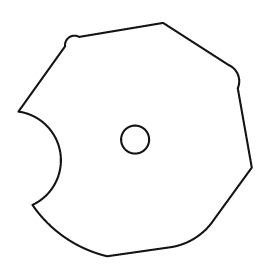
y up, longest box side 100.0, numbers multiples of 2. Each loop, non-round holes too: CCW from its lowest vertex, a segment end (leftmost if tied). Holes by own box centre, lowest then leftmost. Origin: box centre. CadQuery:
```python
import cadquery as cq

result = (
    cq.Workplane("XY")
    .moveTo(-12.0, -50.0)
    .lineTo(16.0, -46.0)
    .threePointArc((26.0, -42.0), (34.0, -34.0))
    .lineTo(50.0, -12.0)
    .lineTo(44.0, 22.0)
    .threePointArc((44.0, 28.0), (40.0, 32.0))
    .lineTo(12.0, 50.0)
    .lineTo(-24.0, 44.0)
    .threePointArc((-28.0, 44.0), (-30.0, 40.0))
    .lineTo(-50.0, 12.0)
    .threePointArc((-32.0, -6.0), (-44.0, -28.0))
    .threePointArc((-30.0, -42.0), (-12.0, -50.0))
    .close()
    .moveTo(0.0, 0.0)
    .circle(6.0)
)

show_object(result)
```